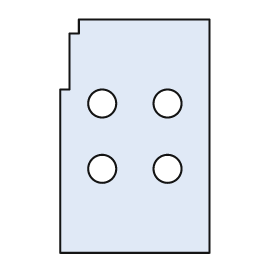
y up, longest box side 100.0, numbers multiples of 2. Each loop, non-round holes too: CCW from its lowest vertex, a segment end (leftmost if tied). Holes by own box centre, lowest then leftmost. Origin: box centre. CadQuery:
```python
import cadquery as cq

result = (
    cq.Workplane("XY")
    .moveTo(-32.0, -50.0)
    .lineTo(32.0, -50.0)
    .lineTo(32.0, 50.0)
    .lineTo(-24.0, 50.0)
    .lineTo(-24.0, 44.0)
    .lineTo(-28.0, 44.0)
    .lineTo(-28.0, 20.0)
    .lineTo(-32.0, 20.0)
    .close()
    .moveTo(-14.0, -14.0)
    .circle(6.0)
    .moveTo(14.0, -14.0)
    .circle(6.0)
    .moveTo(-14.0, 14.0)
    .circle(6.0)
    .moveTo(14.0, 14.0)
    .circle(6.0)
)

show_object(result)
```